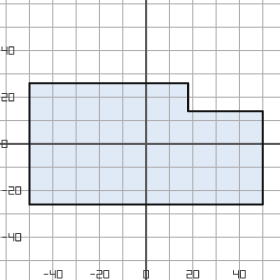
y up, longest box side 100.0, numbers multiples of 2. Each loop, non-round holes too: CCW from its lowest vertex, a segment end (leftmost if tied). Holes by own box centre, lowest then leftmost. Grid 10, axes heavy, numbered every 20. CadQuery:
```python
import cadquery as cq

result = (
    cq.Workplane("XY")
    .moveTo(-50.0, -26.0)
    .lineTo(50.0, -26.0)
    .lineTo(50.0, 14.0)
    .lineTo(18.0, 14.0)
    .lineTo(18.0, 26.0)
    .lineTo(-50.0, 26.0)
    .close()
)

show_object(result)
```